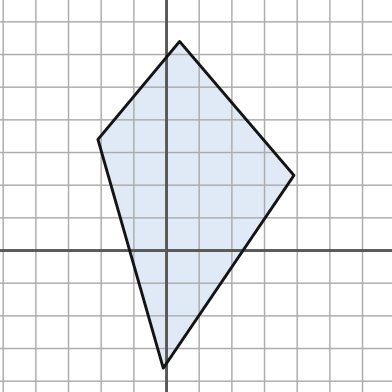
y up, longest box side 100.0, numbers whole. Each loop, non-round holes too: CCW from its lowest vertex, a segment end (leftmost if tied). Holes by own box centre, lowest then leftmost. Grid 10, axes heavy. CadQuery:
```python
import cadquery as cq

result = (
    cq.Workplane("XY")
    .moveTo(-1.0, -36.0)
    .lineTo(39.0, 23.0)
    .lineTo(4.0, 64.0)
    .lineTo(-21.0, 34.0)
    .close()
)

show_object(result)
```